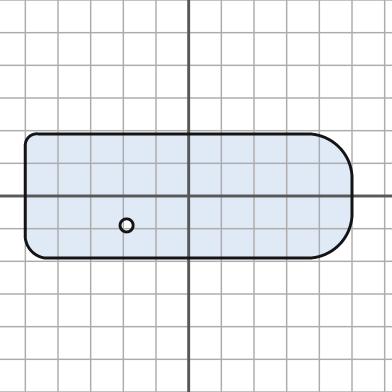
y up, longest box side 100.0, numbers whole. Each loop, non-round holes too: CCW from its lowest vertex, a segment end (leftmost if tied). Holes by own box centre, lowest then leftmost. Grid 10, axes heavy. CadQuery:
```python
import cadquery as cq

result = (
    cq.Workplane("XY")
    .moveTo(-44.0, -19.0)
    .lineTo(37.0, -19.0)
    .threePointArc((46.0, -15.0), (50.0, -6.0))
    .lineTo(50.0, 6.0)
    .threePointArc((46.0, 15.0), (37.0, 19.0))
    .lineTo(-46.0, 19.0)
    .threePointArc((-49.0, 18.0), (-50.0, 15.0))
    .lineTo(-50.0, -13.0)
    .threePointArc((-48.0, -17.0), (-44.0, -19.0))
    .close()
    .moveTo(-19.0, -9.0)
    .circle(2.0)
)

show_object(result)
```